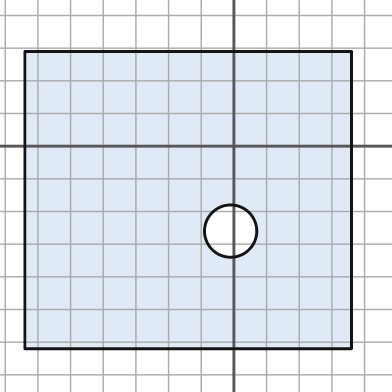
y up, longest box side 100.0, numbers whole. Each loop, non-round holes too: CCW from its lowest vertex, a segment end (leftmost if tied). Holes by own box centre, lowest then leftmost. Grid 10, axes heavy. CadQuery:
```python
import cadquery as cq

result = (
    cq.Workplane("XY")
    .moveTo(-64.0, -62.0)
    .lineTo(36.0, -62.0)
    .lineTo(36.0, 29.0)
    .lineTo(-64.0, 29.0)
    .close()
    .moveTo(-1.0, -26.0)
    .circle(8.0)
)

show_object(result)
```